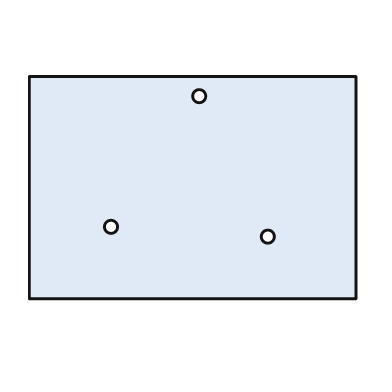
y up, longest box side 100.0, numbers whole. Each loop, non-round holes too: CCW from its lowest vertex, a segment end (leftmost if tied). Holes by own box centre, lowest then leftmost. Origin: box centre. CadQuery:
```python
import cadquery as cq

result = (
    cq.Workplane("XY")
    .moveTo(-50.0, -34.0)
    .lineTo(50.0, -34.0)
    .lineTo(50.0, 34.0)
    .lineTo(-50.0, 34.0)
    .close()
    .moveTo(23.0, -15.0)
    .circle(2.0)
    .moveTo(-25.0, -12.0)
    .circle(2.0)
    .moveTo(2.0, 28.0)
    .circle(2.0)
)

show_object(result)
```